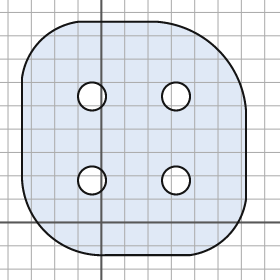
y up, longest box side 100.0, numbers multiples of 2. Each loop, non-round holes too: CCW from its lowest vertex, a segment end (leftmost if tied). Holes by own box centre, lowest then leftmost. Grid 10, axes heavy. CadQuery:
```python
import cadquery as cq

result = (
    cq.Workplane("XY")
    .moveTo(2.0, -14.0)
    .lineTo(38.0, -14.0)
    .threePointArc((54.0, -6.0), (62.0, 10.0))
    .lineTo(62.0, 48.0)
    .threePointArc((50.0, 74.0), (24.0, 86.0))
    .lineTo(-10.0, 86.0)
    .threePointArc((-26.0, 78.0), (-34.0, 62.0))
    .lineTo(-34.0, 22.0)
    .threePointArc((-24.0, -4.0), (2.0, -14.0))
    .close()
    .moveTo(-4.0, 18.0)
    .circle(6.0)
    .moveTo(32.0, 18.0)
    .circle(6.0)
    .moveTo(-4.0, 54.0)
    .circle(6.0)
    .moveTo(32.0, 54.0)
    .circle(6.0)
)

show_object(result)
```